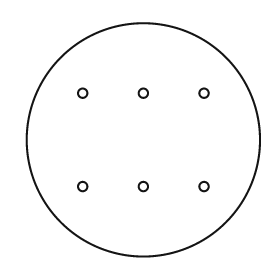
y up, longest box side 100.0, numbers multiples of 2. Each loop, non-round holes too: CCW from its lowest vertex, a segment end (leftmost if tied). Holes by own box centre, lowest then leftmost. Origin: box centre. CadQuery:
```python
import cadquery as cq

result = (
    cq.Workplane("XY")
    .moveTo(0.0, 0.0)
    .circle(50.0)
    .moveTo(-26.0, -20.0)
    .circle(2.0)
    .moveTo(0.0, -20.0)
    .circle(2.0)
    .moveTo(26.0, -20.0)
    .circle(2.0)
    .moveTo(-26.0, 20.0)
    .circle(2.0)
    .moveTo(0.0, 20.0)
    .circle(2.0)
    .moveTo(26.0, 20.0)
    .circle(2.0)
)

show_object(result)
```